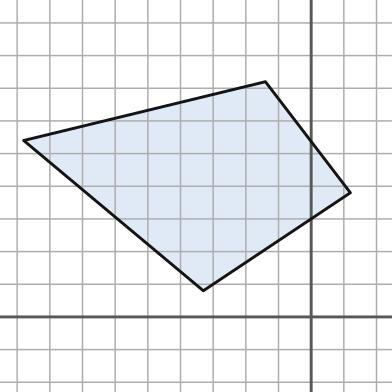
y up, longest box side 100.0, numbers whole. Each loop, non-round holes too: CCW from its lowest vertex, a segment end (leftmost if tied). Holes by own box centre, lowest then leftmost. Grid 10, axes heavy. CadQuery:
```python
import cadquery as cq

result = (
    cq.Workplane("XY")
    .moveTo(-33.0, 8.0)
    .lineTo(12.0, 38.0)
    .lineTo(-14.0, 72.0)
    .lineTo(-88.0, 54.0)
    .close()
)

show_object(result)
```